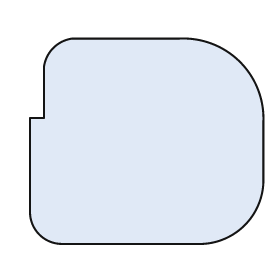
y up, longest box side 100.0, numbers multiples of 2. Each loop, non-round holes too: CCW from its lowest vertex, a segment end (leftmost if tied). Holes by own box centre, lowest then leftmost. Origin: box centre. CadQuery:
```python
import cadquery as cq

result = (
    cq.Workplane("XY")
    .moveTo(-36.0, -44.0)
    .lineTo(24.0, -44.0)
    .threePointArc((42.0, -36.0), (50.0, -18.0))
    .lineTo(50.0, 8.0)
    .threePointArc((40.0, 34.0), (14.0, 44.0))
    .lineTo(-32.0, 44.0)
    .threePointArc((-40.0, 40.0), (-44.0, 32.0))
    .lineTo(-44.0, 10.0)
    .lineTo(-50.0, 10.0)
    .lineTo(-50.0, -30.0)
    .threePointArc((-46.0, -40.0), (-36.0, -44.0))
    .close()
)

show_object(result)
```